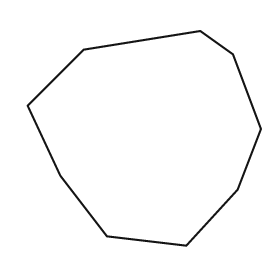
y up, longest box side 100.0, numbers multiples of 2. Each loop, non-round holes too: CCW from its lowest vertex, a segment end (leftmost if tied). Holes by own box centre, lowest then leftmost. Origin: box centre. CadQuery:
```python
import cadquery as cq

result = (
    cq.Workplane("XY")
    .moveTo(18.0, -46.0)
    .lineTo(40.0, -22.0)
    .lineTo(50.0, 4.0)
    .lineTo(38.0, 36.0)
    .lineTo(24.0, 46.0)
    .lineTo(-26.0, 38.0)
    .lineTo(-50.0, 14.0)
    .lineTo(-36.0, -16.0)
    .lineTo(-16.0, -42.0)
    .close()
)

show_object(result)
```